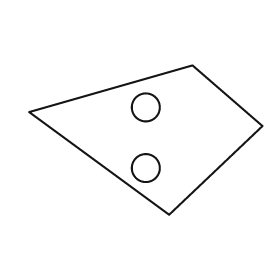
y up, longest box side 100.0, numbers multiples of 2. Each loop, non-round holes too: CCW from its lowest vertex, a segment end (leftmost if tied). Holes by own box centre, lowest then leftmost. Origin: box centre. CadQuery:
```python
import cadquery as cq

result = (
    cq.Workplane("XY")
    .moveTo(10.0, -32.0)
    .lineTo(50.0, 6.0)
    .lineTo(20.0, 32.0)
    .lineTo(-50.0, 12.0)
    .close()
    .moveTo(0.0, -12.0)
    .circle(6.0)
    .moveTo(0.0, 14.0)
    .circle(6.0)
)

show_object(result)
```